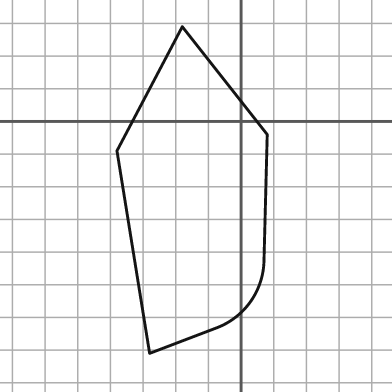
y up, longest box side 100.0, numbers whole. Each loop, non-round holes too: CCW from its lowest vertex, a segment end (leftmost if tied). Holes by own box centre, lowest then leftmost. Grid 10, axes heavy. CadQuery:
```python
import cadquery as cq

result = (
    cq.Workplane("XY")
    .moveTo(-28.0, -71.0)
    .lineTo(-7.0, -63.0)
    .threePointArc((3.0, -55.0), (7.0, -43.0))
    .lineTo(8.0, -4.0)
    .lineTo(-18.0, 29.0)
    .lineTo(-38.0, -9.0)
    .close()
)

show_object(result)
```